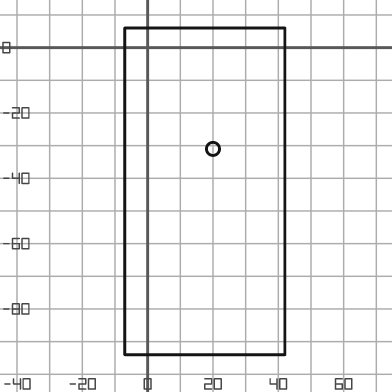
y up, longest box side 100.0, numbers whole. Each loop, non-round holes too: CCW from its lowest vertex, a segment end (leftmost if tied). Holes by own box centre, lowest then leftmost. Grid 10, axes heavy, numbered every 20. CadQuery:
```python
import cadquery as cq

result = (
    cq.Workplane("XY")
    .moveTo(-7.0, -94.0)
    .lineTo(42.0, -94.0)
    .lineTo(42.0, 6.0)
    .lineTo(-7.0, 6.0)
    .close()
    .moveTo(20.0, -31.0)
    .circle(2.0)
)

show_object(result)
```